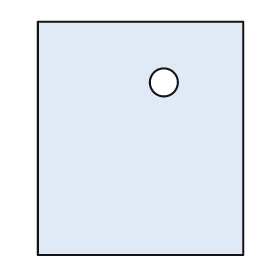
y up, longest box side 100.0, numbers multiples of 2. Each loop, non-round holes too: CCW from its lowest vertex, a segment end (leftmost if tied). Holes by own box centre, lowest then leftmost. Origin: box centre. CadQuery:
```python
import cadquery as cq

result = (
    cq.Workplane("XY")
    .moveTo(-44.0, -50.0)
    .lineTo(44.0, -50.0)
    .lineTo(44.0, 50.0)
    .lineTo(-44.0, 50.0)
    .close()
    .moveTo(10.0, 24.0)
    .circle(6.0)
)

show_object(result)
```